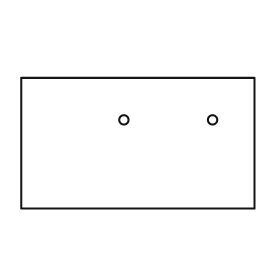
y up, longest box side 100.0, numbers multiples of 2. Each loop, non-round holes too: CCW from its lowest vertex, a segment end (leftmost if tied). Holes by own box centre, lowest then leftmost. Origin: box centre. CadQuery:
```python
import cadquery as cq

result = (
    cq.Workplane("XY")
    .moveTo(-50.0, -28.0)
    .lineTo(50.0, -28.0)
    .lineTo(50.0, 28.0)
    .lineTo(-50.0, 28.0)
    .close()
    .moveTo(-6.0, 10.0)
    .circle(2.0)
    .moveTo(32.0, 10.0)
    .circle(2.0)
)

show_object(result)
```